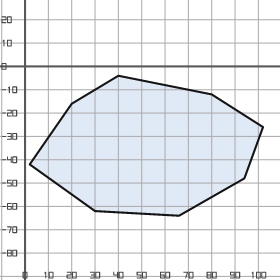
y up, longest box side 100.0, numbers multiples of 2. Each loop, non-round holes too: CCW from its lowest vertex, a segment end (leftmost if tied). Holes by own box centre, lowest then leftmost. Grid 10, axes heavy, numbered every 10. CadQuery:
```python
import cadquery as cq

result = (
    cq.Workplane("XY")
    .moveTo(66.0, -64.0)
    .lineTo(94.0, -48.0)
    .lineTo(102.0, -26.0)
    .lineTo(80.0, -12.0)
    .lineTo(40.0, -4.0)
    .lineTo(20.0, -16.0)
    .lineTo(2.0, -42.0)
    .lineTo(30.0, -62.0)
    .close()
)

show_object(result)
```